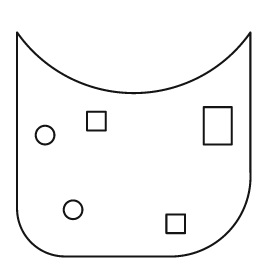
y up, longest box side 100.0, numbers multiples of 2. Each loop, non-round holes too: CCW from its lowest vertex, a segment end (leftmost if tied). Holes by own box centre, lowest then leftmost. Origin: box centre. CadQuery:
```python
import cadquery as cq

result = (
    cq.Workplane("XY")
    .moveTo(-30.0, -48.0)
    .lineTo(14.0, -48.0)
    .threePointArc((40.0, -38.0), (50.0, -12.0))
    .lineTo(50.0, 48.0)
    .threePointArc((0.0, 22.0), (-50.0, 48.0))
    .lineTo(-50.0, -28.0)
    .threePointArc((-44.0, -42.0), (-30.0, -48.0))
    .close()
    .moveTo(14.0, -38.0)
    .lineTo(22.0, -38.0)
    .lineTo(22.0, -30.0)
    .lineTo(14.0, -30.0)
    .close()
    .moveTo(-26.0, -28.0)
    .circle(4.0)
    .moveTo(-38.0, 4.0)
    .circle(4.0)
    .moveTo(30.0, 0.0)
    .lineTo(42.0, 0.0)
    .lineTo(42.0, 16.0)
    .lineTo(30.0, 16.0)
    .close()
    .moveTo(-20.0, 6.0)
    .lineTo(-12.0, 6.0)
    .lineTo(-12.0, 14.0)
    .lineTo(-20.0, 14.0)
    .close()
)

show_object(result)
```